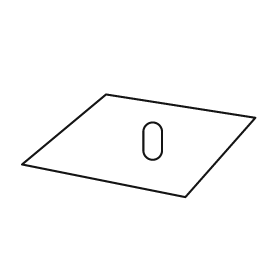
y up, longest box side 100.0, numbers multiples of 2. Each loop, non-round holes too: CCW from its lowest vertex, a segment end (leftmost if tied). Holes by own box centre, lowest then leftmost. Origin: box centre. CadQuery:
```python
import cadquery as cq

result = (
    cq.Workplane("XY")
    .moveTo(20.0, -22.0)
    .lineTo(50.0, 12.0)
    .lineTo(-14.0, 22.0)
    .lineTo(-50.0, -8.0)
    .close()
    .moveTo(2.0, -2.0)
    .threePointArc((6.0, -6.0), (10.0, -2.0))
    .lineTo(10.0, 6.0)
    .threePointArc((6.0, 10.0), (2.0, 6.0))
    .close()
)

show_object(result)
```